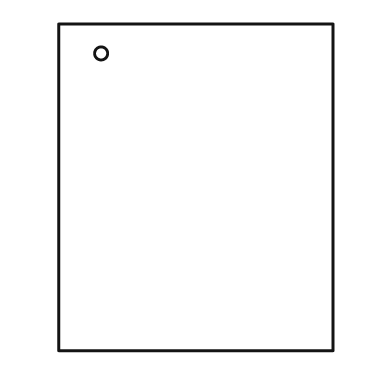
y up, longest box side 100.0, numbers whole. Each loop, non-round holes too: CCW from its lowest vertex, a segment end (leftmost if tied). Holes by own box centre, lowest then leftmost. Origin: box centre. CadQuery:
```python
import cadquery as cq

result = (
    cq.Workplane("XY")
    .moveTo(-42.0, -50.0)
    .lineTo(42.0, -50.0)
    .lineTo(42.0, 50.0)
    .lineTo(-42.0, 50.0)
    .close()
    .moveTo(-29.0, 41.0)
    .circle(2.0)
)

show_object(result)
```